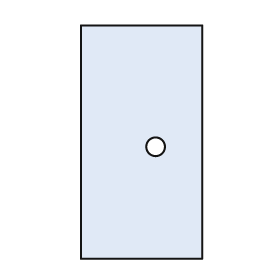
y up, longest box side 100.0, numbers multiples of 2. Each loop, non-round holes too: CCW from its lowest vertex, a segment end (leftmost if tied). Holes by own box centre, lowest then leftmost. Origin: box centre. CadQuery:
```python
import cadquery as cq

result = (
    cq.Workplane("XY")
    .moveTo(-26.0, -50.0)
    .lineTo(26.0, -50.0)
    .lineTo(26.0, 50.0)
    .lineTo(-26.0, 50.0)
    .close()
    .moveTo(6.0, -2.0)
    .circle(4.0)
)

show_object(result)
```